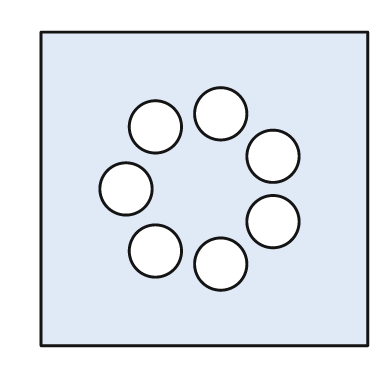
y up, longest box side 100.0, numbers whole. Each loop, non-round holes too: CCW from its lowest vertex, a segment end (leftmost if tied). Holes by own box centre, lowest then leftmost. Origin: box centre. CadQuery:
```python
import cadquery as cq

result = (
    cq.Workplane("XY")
    .moveTo(-50.0, -48.0)
    .lineTo(50.0, -48.0)
    .lineTo(50.0, 48.0)
    .lineTo(-50.0, 48.0)
    .close()
    .moveTo(5.0, -23.0)
    .circle(8.0)
    .moveTo(-15.0, -19.0)
    .circle(8.0)
    .moveTo(21.0, -10.0)
    .circle(8.0)
    .moveTo(-24.0, 0.0)
    .circle(8.0)
    .moveTo(21.0, 10.0)
    .circle(8.0)
    .moveTo(-15.0, 19.0)
    .circle(8.0)
    .moveTo(5.0, 23.0)
    .circle(8.0)
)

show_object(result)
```